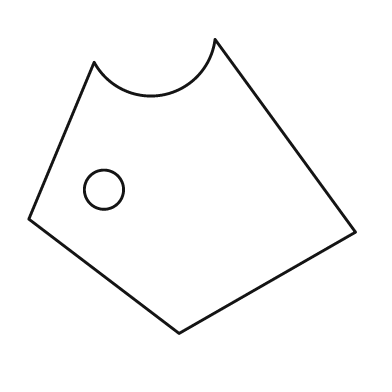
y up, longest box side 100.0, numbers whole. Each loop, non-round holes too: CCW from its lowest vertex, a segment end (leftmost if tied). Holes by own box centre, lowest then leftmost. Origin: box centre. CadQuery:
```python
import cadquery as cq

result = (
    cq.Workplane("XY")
    .moveTo(-4.0, -45.0)
    .lineTo(50.0, -14.0)
    .lineTo(7.0, 45.0)
    .threePointArc((-9.0, 28.0), (-30.0, 38.0))
    .lineTo(-50.0, -10.0)
    .close()
    .moveTo(-27.0, -1.0)
    .circle(6.0)
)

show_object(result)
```